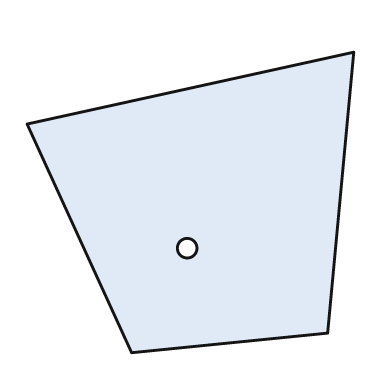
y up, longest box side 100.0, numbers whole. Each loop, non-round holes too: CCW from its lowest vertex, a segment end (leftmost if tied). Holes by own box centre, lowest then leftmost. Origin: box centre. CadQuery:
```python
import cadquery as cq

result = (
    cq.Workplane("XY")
    .moveTo(-18.0, -46.0)
    .lineTo(42.0, -40.0)
    .lineTo(50.0, 46.0)
    .lineTo(-50.0, 24.0)
    .close()
    .moveTo(-1.0, -14.0)
    .circle(3.0)
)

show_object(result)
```